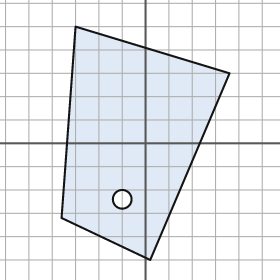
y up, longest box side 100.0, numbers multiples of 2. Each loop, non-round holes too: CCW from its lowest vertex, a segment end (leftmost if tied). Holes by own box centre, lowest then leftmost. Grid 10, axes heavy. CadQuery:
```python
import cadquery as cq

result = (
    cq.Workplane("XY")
    .moveTo(2.0, -50.0)
    .lineTo(36.0, 30.0)
    .lineTo(-30.0, 50.0)
    .lineTo(-36.0, -32.0)
    .close()
    .moveTo(-10.0, -24.0)
    .circle(4.0)
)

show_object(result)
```